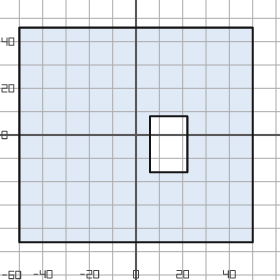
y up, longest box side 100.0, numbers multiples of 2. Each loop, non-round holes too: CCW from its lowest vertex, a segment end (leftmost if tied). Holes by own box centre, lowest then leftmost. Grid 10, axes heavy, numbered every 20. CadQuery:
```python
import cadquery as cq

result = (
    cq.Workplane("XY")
    .moveTo(-50.0, -46.0)
    .lineTo(50.0, -46.0)
    .lineTo(50.0, 46.0)
    .lineTo(-50.0, 46.0)
    .close()
    .moveTo(6.0, -16.0)
    .lineTo(22.0, -16.0)
    .lineTo(22.0, 8.0)
    .lineTo(6.0, 8.0)
    .close()
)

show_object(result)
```